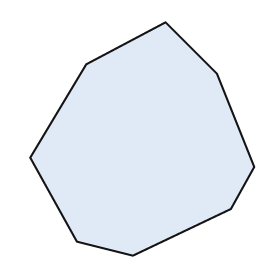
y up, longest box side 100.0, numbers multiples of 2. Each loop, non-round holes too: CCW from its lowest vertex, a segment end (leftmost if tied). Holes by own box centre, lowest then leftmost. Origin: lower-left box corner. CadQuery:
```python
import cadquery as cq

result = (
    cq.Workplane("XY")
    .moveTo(44.0, 0.0)
    .lineTo(86.0, 20.0)
    .lineTo(96.0, 38.0)
    .lineTo(80.0, 78.0)
    .lineTo(58.0, 100.0)
    .lineTo(24.0, 82.0)
    .lineTo(0.0, 42.0)
    .lineTo(20.0, 6.0)
    .close()
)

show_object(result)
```